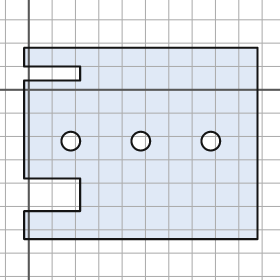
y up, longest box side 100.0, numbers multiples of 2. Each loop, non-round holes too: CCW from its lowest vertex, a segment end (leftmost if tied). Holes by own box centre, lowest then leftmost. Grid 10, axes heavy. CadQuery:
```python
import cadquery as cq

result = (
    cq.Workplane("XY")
    .moveTo(-2.0, -64.0)
    .lineTo(98.0, -64.0)
    .lineTo(98.0, 18.0)
    .lineTo(-2.0, 18.0)
    .lineTo(-2.0, 10.0)
    .lineTo(22.0, 10.0)
    .lineTo(22.0, 4.0)
    .lineTo(-2.0, 4.0)
    .lineTo(-2.0, -38.0)
    .lineTo(22.0, -38.0)
    .lineTo(22.0, -52.0)
    .lineTo(-2.0, -52.0)
    .close()
    .moveTo(18.0, -22.0)
    .circle(4.0)
    .moveTo(48.0, -22.0)
    .circle(4.0)
    .moveTo(78.0, -22.0)
    .circle(4.0)
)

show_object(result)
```